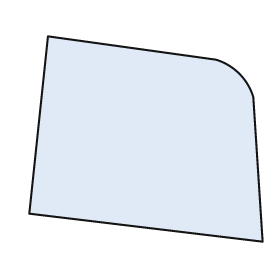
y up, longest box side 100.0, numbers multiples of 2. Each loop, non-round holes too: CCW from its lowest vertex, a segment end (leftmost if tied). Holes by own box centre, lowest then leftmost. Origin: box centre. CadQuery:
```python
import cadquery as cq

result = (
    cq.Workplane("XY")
    .moveTo(50.0, -44.0)
    .lineTo(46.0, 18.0)
    .threePointArc((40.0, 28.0), (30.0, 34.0))
    .lineTo(-42.0, 44.0)
    .lineTo(-50.0, -32.0)
    .close()
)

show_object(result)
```